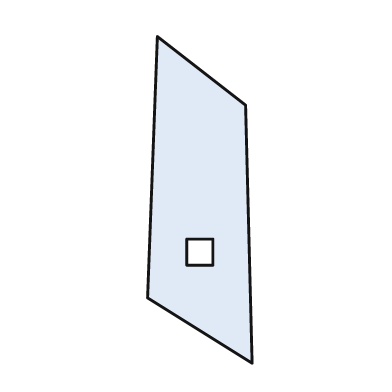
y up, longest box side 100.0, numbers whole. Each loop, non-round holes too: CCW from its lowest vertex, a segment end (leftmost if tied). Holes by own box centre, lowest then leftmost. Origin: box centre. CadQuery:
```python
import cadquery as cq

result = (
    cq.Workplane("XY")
    .moveTo(16.0, -50.0)
    .lineTo(14.0, 29.0)
    .lineTo(-13.0, 50.0)
    .lineTo(-16.0, -30.0)
    .close()
    .moveTo(-4.0, -20.0)
    .lineTo(4.0, -20.0)
    .lineTo(4.0, -12.0)
    .lineTo(-4.0, -12.0)
    .close()
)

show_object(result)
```